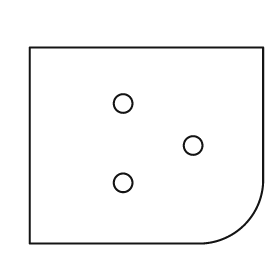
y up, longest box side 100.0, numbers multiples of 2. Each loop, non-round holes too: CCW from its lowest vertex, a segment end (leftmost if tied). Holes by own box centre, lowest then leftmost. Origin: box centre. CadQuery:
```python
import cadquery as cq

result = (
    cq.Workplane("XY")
    .moveTo(-50.0, -42.0)
    .lineTo(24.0, -42.0)
    .threePointArc((42.0, -34.0), (50.0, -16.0))
    .lineTo(50.0, 42.0)
    .lineTo(-50.0, 42.0)
    .close()
    .moveTo(-10.0, -16.0)
    .circle(4.0)
    .moveTo(20.0, 0.0)
    .circle(4.0)
    .moveTo(-10.0, 18.0)
    .circle(4.0)
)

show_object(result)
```